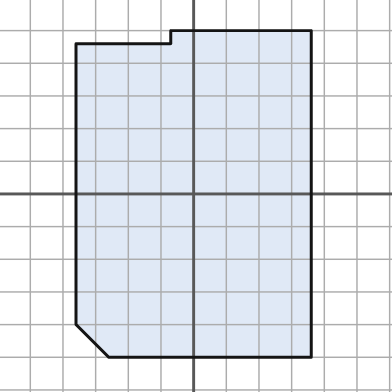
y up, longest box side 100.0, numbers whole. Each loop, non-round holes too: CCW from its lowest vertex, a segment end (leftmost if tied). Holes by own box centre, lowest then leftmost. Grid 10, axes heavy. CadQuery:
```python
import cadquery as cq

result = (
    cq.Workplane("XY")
    .moveTo(-26.0, -50.0)
    .lineTo(36.0, -50.0)
    .lineTo(36.0, 50.0)
    .lineTo(-7.0, 50.0)
    .lineTo(-7.0, 46.0)
    .lineTo(-36.0, 46.0)
    .lineTo(-36.0, -40.0)
    .close()
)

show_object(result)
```